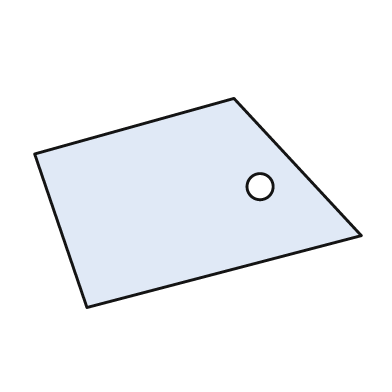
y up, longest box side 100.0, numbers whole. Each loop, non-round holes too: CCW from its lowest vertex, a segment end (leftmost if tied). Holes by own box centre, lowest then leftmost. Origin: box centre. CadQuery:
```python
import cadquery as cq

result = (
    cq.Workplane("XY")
    .moveTo(-34.0, -32.0)
    .lineTo(50.0, -10.0)
    .lineTo(11.0, 32.0)
    .lineTo(-50.0, 15.0)
    .close()
    .moveTo(19.0, 5.0)
    .circle(4.0)
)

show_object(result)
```